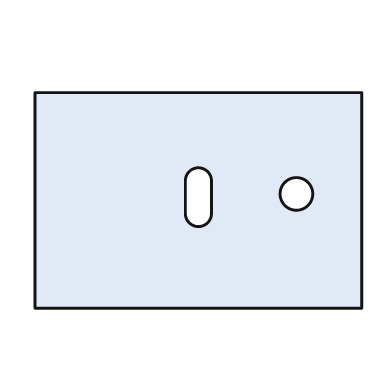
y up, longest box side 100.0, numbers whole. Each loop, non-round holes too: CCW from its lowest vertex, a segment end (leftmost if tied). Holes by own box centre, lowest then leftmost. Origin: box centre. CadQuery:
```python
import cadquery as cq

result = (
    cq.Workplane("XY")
    .moveTo(-50.0, -33.0)
    .lineTo(50.0, -33.0)
    .lineTo(50.0, 33.0)
    .lineTo(-50.0, 33.0)
    .close()
    .moveTo(-4.0, -4.0)
    .threePointArc((0.0, -8.0), (4.0, -4.0))
    .lineTo(4.0, 6.0)
    .threePointArc((0.0, 10.0), (-4.0, 6.0))
    .close()
    .moveTo(30.0, 2.0)
    .circle(5.0)
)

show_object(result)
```